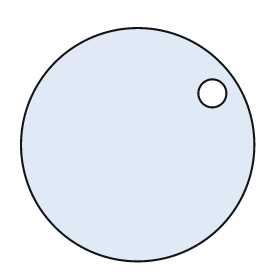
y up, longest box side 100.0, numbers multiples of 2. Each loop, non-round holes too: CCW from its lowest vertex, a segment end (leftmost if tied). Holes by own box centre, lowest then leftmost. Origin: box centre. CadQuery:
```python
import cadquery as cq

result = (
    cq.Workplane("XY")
    .moveTo(0.0, 0.0)
    .circle(50.0)
    .moveTo(32.0, 22.0)
    .circle(6.0)
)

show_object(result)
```